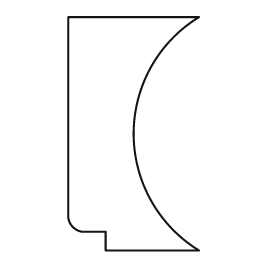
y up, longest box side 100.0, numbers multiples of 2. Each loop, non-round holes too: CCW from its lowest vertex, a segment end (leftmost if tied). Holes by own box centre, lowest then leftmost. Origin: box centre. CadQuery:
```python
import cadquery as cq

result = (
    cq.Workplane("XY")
    .moveTo(-12.0, -50.0)
    .lineTo(28.0, -50.0)
    .threePointArc((0.0, 0.0), (28.0, 50.0))
    .lineTo(-28.0, 50.0)
    .lineTo(-28.0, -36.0)
    .threePointArc((-26.0, -40.0), (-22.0, -42.0))
    .lineTo(-12.0, -42.0)
    .close()
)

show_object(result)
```